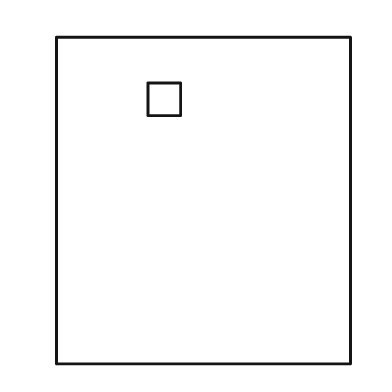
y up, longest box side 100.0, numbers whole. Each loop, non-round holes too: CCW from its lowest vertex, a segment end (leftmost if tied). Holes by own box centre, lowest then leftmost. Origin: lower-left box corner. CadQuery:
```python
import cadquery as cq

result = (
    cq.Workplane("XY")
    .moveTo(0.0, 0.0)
    .lineTo(90.0, 0.0)
    .lineTo(90.0, 100.0)
    .lineTo(0.0, 100.0)
    .close()
    .moveTo(28.0, 76.0)
    .lineTo(38.0, 76.0)
    .lineTo(38.0, 86.0)
    .lineTo(28.0, 86.0)
    .close()
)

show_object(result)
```